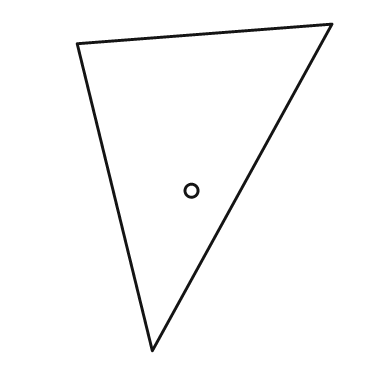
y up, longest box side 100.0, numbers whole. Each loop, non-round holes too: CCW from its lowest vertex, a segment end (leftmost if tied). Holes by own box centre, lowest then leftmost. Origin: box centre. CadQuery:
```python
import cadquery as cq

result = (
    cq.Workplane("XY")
    .moveTo(-16.0, -50.0)
    .lineTo(39.0, 50.0)
    .lineTo(-39.0, 44.0)
    .close()
    .moveTo(-4.0, -1.0)
    .circle(2.0)
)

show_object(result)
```